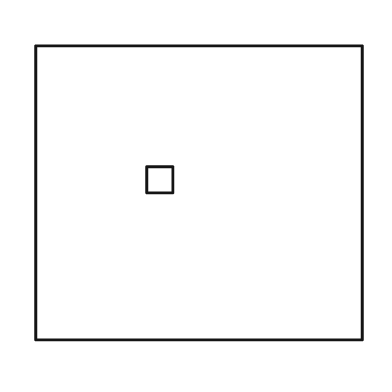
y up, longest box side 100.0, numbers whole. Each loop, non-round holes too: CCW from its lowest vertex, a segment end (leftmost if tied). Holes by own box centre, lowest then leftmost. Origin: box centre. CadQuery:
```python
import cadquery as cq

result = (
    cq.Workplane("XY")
    .moveTo(-50.0, -45.0)
    .lineTo(50.0, -45.0)
    .lineTo(50.0, 45.0)
    .lineTo(-50.0, 45.0)
    .close()
    .moveTo(-16.0, 0.0)
    .lineTo(-8.0, 0.0)
    .lineTo(-8.0, 8.0)
    .lineTo(-16.0, 8.0)
    .close()
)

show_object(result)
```